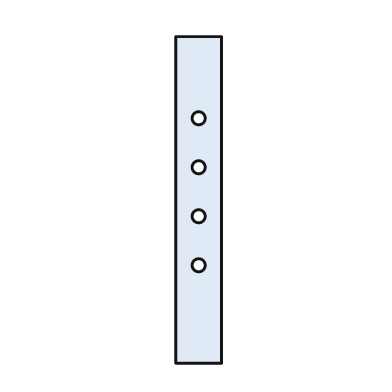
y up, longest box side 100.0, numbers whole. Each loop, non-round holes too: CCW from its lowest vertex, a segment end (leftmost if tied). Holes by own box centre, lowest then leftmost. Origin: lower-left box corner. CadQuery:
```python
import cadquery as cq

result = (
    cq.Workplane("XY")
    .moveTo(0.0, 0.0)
    .lineTo(14.0, 0.0)
    .lineTo(14.0, 100.0)
    .lineTo(0.0, 100.0)
    .close()
    .moveTo(7.0, 30.0)
    .circle(2.0)
    .moveTo(7.0, 45.0)
    .circle(2.0)
    .moveTo(7.0, 60.0)
    .circle(2.0)
    .moveTo(7.0, 75.0)
    .circle(2.0)
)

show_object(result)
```